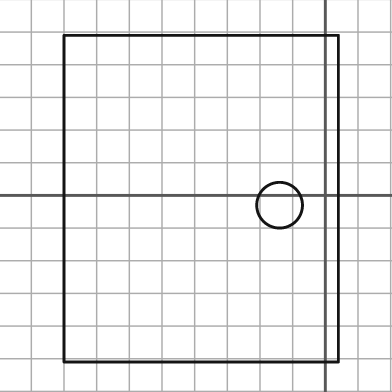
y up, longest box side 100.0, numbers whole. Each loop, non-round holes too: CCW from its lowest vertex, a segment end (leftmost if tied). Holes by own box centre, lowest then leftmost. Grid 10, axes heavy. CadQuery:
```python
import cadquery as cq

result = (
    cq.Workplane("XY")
    .moveTo(-80.0, -51.0)
    .lineTo(4.0, -51.0)
    .lineTo(4.0, 49.0)
    .lineTo(-80.0, 49.0)
    .close()
    .moveTo(-14.0, -3.0)
    .circle(7.0)
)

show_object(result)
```